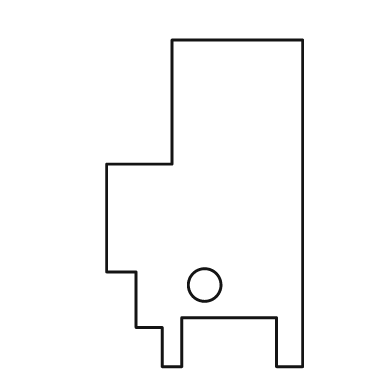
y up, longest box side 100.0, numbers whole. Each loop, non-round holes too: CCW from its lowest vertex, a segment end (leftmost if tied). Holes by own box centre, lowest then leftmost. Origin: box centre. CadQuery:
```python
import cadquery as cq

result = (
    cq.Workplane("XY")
    .moveTo(-13.0, -50.0)
    .lineTo(-7.0, -50.0)
    .lineTo(-7.0, -35.0)
    .lineTo(22.0, -35.0)
    .lineTo(22.0, -50.0)
    .lineTo(30.0, -50.0)
    .lineTo(30.0, 50.0)
    .lineTo(-10.0, 50.0)
    .lineTo(-10.0, 12.0)
    .lineTo(-30.0, 12.0)
    .lineTo(-30.0, -21.0)
    .lineTo(-21.0, -21.0)
    .lineTo(-21.0, -38.0)
    .lineTo(-13.0, -38.0)
    .close()
    .moveTo(0.0, -25.0)
    .circle(5.0)
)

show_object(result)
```